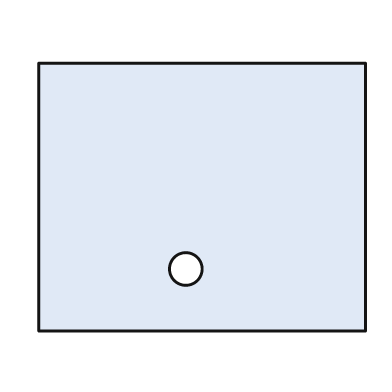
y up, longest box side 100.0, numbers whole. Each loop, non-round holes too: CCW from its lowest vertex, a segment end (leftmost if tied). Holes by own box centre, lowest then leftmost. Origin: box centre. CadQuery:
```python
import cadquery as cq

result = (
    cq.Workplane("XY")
    .moveTo(-50.0, -41.0)
    .lineTo(50.0, -41.0)
    .lineTo(50.0, 41.0)
    .lineTo(-50.0, 41.0)
    .close()
    .moveTo(-5.0, -22.0)
    .circle(5.0)
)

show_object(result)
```